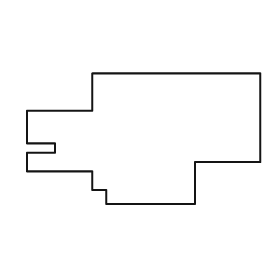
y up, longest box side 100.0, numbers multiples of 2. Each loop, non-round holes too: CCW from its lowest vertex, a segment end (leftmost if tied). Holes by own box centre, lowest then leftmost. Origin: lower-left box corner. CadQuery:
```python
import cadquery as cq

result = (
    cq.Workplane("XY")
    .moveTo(34.0, 0.0)
    .lineTo(72.0, 0.0)
    .lineTo(72.0, 18.0)
    .lineTo(100.0, 18.0)
    .lineTo(100.0, 56.0)
    .lineTo(28.0, 56.0)
    .lineTo(28.0, 40.0)
    .lineTo(0.0, 40.0)
    .lineTo(0.0, 26.0)
    .lineTo(12.0, 26.0)
    .lineTo(12.0, 22.0)
    .lineTo(0.0, 22.0)
    .lineTo(0.0, 14.0)
    .lineTo(28.0, 14.0)
    .lineTo(28.0, 6.0)
    .lineTo(34.0, 6.0)
    .close()
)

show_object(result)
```